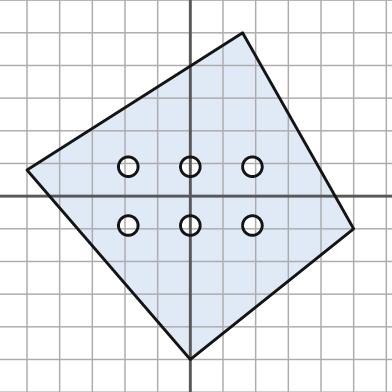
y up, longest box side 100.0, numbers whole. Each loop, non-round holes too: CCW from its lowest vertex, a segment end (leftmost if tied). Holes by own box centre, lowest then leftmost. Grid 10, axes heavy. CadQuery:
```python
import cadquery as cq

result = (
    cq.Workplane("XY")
    .moveTo(0.0, -50.0)
    .lineTo(50.0, -10.0)
    .lineTo(16.0, 50.0)
    .lineTo(-50.0, 8.0)
    .close()
    .moveTo(-19.0, -9.0)
    .circle(3.0)
    .moveTo(0.0, -9.0)
    .circle(3.0)
    .moveTo(19.0, -9.0)
    .circle(3.0)
    .moveTo(-19.0, 9.0)
    .circle(3.0)
    .moveTo(0.0, 9.0)
    .circle(3.0)
    .moveTo(19.0, 9.0)
    .circle(3.0)
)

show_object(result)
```